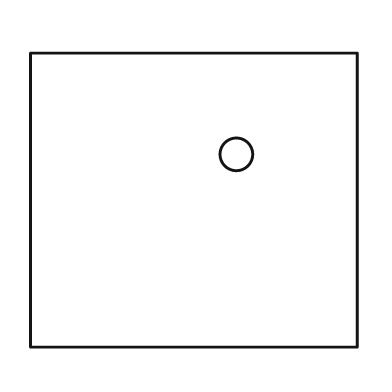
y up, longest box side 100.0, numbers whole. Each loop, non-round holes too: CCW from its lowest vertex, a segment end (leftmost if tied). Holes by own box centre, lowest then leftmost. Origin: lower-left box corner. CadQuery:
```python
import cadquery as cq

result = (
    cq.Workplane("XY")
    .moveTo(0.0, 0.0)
    .lineTo(100.0, 0.0)
    .lineTo(100.0, 90.0)
    .lineTo(0.0, 90.0)
    .close()
    .moveTo(63.0, 59.0)
    .circle(5.0)
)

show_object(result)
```